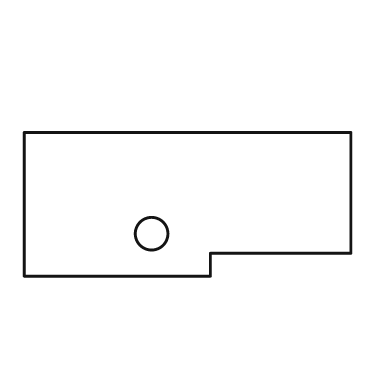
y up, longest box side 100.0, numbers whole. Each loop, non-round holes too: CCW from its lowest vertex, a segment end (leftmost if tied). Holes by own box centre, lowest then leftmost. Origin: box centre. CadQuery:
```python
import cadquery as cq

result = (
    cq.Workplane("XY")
    .moveTo(-50.0, -22.0)
    .lineTo(7.0, -22.0)
    .lineTo(7.0, -15.0)
    .lineTo(50.0, -15.0)
    .lineTo(50.0, 22.0)
    .lineTo(-50.0, 22.0)
    .close()
    .moveTo(-11.0, -9.0)
    .circle(5.0)
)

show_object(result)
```